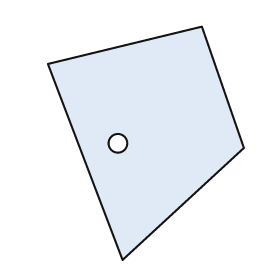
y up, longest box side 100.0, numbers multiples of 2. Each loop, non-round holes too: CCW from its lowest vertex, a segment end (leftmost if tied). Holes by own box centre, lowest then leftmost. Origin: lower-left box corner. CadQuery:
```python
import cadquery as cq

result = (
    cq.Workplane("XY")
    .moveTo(32.0, 0.0)
    .lineTo(84.0, 48.0)
    .lineTo(66.0, 100.0)
    .lineTo(0.0, 84.0)
    .close()
    .moveTo(30.0, 50.0)
    .circle(4.0)
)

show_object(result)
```